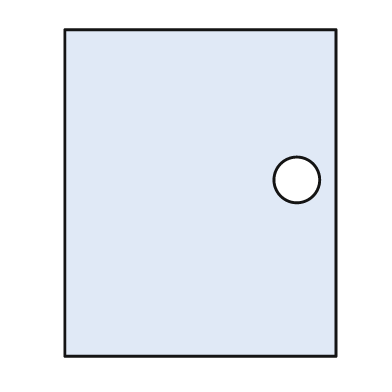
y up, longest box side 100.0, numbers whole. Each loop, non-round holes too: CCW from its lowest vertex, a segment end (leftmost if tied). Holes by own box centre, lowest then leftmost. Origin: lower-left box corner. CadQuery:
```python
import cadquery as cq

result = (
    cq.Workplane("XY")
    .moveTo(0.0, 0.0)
    .lineTo(83.0, 0.0)
    .lineTo(83.0, 100.0)
    .lineTo(0.0, 100.0)
    .close()
    .moveTo(71.0, 54.0)
    .circle(7.0)
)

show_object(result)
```